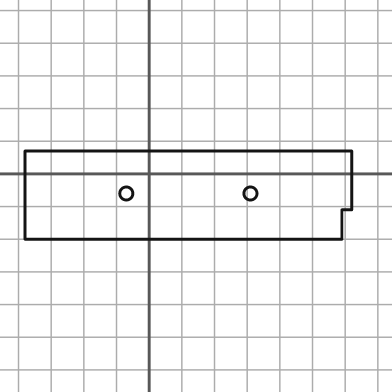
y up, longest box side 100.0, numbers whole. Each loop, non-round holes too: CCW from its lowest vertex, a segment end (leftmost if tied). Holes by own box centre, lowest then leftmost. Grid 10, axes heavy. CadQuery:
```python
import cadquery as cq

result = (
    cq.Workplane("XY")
    .moveTo(-38.0, -20.0)
    .lineTo(59.0, -20.0)
    .lineTo(59.0, -11.0)
    .lineTo(62.0, -11.0)
    .lineTo(62.0, 7.0)
    .lineTo(-38.0, 7.0)
    .close()
    .moveTo(-7.0, -6.0)
    .circle(2.0)
    .moveTo(31.0, -6.0)
    .circle(2.0)
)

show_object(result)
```